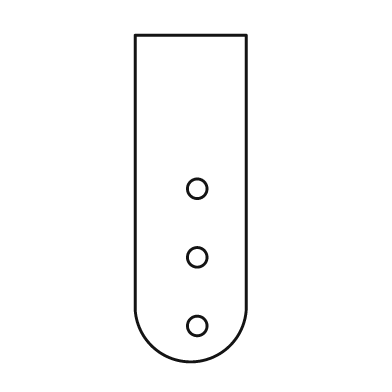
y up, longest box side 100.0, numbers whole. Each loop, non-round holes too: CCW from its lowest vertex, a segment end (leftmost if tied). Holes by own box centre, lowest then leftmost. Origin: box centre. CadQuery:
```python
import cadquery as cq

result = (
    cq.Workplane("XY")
    .moveTo(-17.0, -34.0)
    .threePointArc((0.0, -50.0), (17.0, -34.0))
    .lineTo(17.0, 50.0)
    .lineTo(-17.0, 50.0)
    .close()
    .moveTo(2.0, -39.0)
    .circle(3.0)
    .moveTo(2.0, -18.0)
    .circle(3.0)
    .moveTo(2.0, 3.0)
    .circle(3.0)
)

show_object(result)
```